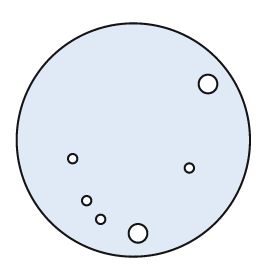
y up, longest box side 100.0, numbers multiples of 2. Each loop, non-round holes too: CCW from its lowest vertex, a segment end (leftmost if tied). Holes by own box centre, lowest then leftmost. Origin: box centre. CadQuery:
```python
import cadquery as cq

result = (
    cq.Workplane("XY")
    .moveTo(0.0, 0.0)
    .circle(50.0)
    .moveTo(2.0, -40.0)
    .circle(4.0)
    .moveTo(-14.0, -34.0)
    .circle(2.0)
    .moveTo(-20.0, -26.0)
    .circle(2.0)
    .moveTo(24.0, -12.0)
    .circle(2.0)
    .moveTo(-26.0, -8.0)
    .circle(2.0)
    .moveTo(32.0, 24.0)
    .circle(4.0)
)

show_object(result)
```